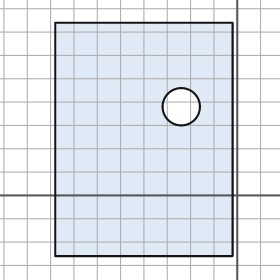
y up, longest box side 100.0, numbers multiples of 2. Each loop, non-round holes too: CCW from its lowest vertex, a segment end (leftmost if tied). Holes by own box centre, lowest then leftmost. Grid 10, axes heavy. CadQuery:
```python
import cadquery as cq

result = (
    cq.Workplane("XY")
    .moveTo(-78.0, -26.0)
    .lineTo(-2.0, -26.0)
    .lineTo(-2.0, 74.0)
    .lineTo(-78.0, 74.0)
    .close()
    .moveTo(-24.0, 38.0)
    .circle(8.0)
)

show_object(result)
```